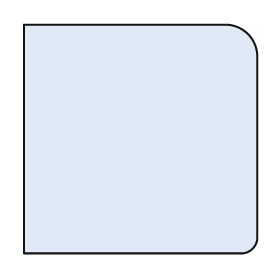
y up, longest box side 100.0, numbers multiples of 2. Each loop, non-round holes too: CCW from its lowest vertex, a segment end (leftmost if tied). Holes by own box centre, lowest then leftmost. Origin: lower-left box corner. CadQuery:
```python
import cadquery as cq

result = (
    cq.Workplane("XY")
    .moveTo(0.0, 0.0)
    .lineTo(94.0, 0.0)
    .threePointArc((98.0, 2.0), (100.0, 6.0))
    .lineTo(100.0, 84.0)
    .threePointArc((96.0, 94.0), (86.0, 98.0))
    .lineTo(0.0, 98.0)
    .close()
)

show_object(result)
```